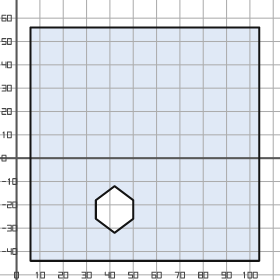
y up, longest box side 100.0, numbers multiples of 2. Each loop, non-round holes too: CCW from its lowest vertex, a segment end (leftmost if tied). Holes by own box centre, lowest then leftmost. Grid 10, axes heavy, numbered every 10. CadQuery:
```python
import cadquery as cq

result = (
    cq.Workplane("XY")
    .moveTo(6.0, -44.0)
    .lineTo(104.0, -44.0)
    .lineTo(104.0, 56.0)
    .lineTo(6.0, 56.0)
    .close()
    .moveTo(42.0, -32.0)
    .lineTo(50.0, -26.0)
    .lineTo(50.0, -18.0)
    .lineTo(42.0, -12.0)
    .lineTo(34.0, -18.0)
    .lineTo(34.0, -26.0)
    .close()
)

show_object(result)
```